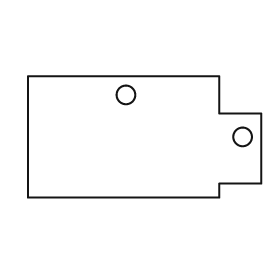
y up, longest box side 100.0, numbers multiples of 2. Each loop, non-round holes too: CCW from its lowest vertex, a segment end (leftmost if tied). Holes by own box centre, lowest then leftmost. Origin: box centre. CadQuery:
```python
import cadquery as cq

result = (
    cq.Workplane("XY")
    .moveTo(-50.0, -26.0)
    .lineTo(32.0, -26.0)
    .lineTo(32.0, -20.0)
    .lineTo(50.0, -20.0)
    .lineTo(50.0, 10.0)
    .lineTo(32.0, 10.0)
    .lineTo(32.0, 26.0)
    .lineTo(-50.0, 26.0)
    .close()
    .moveTo(42.0, 0.0)
    .circle(4.0)
    .moveTo(-8.0, 18.0)
    .circle(4.0)
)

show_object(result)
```